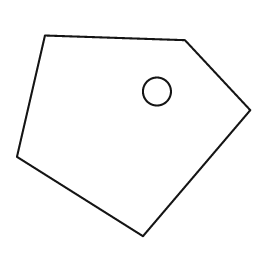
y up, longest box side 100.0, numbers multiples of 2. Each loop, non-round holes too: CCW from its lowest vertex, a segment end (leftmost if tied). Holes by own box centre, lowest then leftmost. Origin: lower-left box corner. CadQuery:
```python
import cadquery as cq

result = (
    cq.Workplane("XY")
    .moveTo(54.0, 0.0)
    .lineTo(100.0, 54.0)
    .lineTo(72.0, 84.0)
    .lineTo(12.0, 86.0)
    .lineTo(0.0, 34.0)
    .close()
    .moveTo(60.0, 62.0)
    .circle(6.0)
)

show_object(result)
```